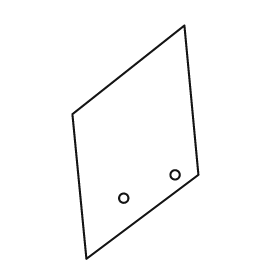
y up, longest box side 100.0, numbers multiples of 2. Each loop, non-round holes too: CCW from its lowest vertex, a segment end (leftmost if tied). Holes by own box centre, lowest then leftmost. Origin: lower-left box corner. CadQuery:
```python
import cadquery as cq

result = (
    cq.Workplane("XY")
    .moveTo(6.0, 0.0)
    .lineTo(54.0, 36.0)
    .lineTo(48.0, 100.0)
    .lineTo(0.0, 62.0)
    .close()
    .moveTo(22.0, 26.0)
    .circle(2.0)
    .moveTo(44.0, 36.0)
    .circle(2.0)
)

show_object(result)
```